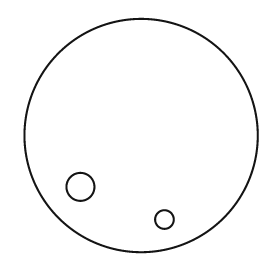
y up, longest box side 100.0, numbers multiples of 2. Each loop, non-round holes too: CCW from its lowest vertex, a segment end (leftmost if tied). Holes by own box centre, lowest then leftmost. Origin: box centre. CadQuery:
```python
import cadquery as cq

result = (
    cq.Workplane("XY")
    .moveTo(0.0, 0.0)
    .circle(50.0)
    .moveTo(10.0, -36.0)
    .circle(4.0)
    .moveTo(-26.0, -22.0)
    .circle(6.0)
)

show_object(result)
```